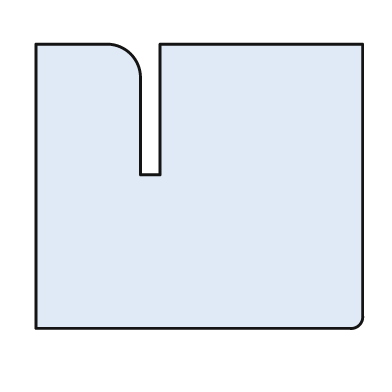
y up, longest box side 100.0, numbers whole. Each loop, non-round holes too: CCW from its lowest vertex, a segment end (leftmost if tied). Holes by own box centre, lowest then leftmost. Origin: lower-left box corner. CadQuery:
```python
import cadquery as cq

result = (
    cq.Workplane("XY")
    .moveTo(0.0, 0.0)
    .lineTo(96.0, 0.0)
    .threePointArc((99.0, 1.0), (100.0, 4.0))
    .lineTo(100.0, 87.0)
    .lineTo(38.0, 87.0)
    .lineTo(38.0, 47.0)
    .lineTo(32.0, 47.0)
    .lineTo(32.0, 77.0)
    .threePointArc((29.0, 84.0), (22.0, 87.0))
    .lineTo(0.0, 87.0)
    .close()
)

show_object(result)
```